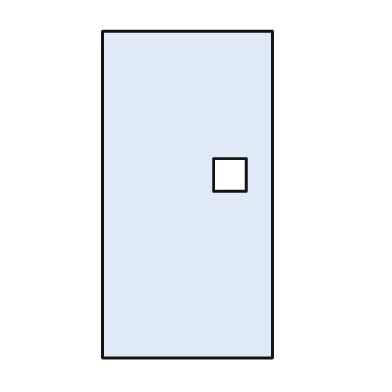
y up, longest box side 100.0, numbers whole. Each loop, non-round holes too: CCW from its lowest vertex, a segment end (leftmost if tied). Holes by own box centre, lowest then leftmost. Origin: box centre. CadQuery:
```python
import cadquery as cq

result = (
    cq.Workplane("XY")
    .moveTo(-26.0, -50.0)
    .lineTo(26.0, -50.0)
    .lineTo(26.0, 50.0)
    .lineTo(-26.0, 50.0)
    .close()
    .moveTo(8.0, 1.0)
    .lineTo(18.0, 1.0)
    .lineTo(18.0, 11.0)
    .lineTo(8.0, 11.0)
    .close()
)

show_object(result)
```